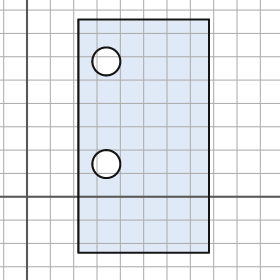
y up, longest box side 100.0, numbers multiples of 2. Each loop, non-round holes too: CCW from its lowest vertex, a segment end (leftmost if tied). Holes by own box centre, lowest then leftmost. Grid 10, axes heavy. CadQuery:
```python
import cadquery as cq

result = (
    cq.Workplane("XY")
    .moveTo(22.0, -24.0)
    .lineTo(78.0, -24.0)
    .lineTo(78.0, 76.0)
    .lineTo(22.0, 76.0)
    .close()
    .moveTo(34.0, 14.0)
    .circle(6.0)
    .moveTo(34.0, 58.0)
    .circle(6.0)
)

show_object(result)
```